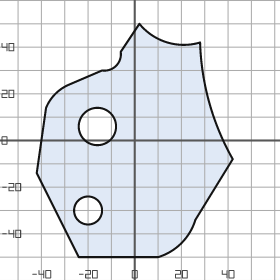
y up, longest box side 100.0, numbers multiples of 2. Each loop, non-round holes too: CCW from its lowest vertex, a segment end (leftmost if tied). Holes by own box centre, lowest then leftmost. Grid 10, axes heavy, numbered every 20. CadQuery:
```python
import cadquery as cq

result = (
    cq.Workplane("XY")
    .moveTo(-24.0, -50.0)
    .lineTo(10.0, -50.0)
    .threePointArc((20.0, -44.0), (26.0, -34.0))
    .lineTo(42.0, -8.0)
    .threePointArc((32.0, 16.0), (28.0, 42.0))
    .threePointArc((14.0, 42.0), (2.0, 50.0))
    .lineTo(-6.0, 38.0)
    .threePointArc((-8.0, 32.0), (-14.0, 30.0))
    .lineTo(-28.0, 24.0)
    .threePointArc((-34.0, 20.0), (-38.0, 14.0))
    .lineTo(-42.0, -14.0)
    .close()
    .moveTo(-20.0, -30.0)
    .circle(6.0)
    .moveTo(-16.0, 6.0)
    .circle(8.0)
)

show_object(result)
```